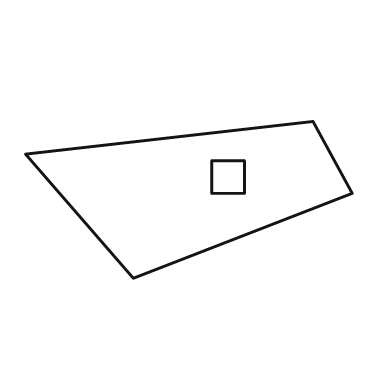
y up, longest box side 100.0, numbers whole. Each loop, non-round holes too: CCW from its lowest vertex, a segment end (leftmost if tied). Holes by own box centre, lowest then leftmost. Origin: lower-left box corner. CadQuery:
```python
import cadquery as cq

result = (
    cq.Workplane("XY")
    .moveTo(33.0, 0.0)
    .lineTo(100.0, 26.0)
    .lineTo(88.0, 48.0)
    .lineTo(0.0, 38.0)
    .close()
    .moveTo(57.0, 26.0)
    .lineTo(67.0, 26.0)
    .lineTo(67.0, 36.0)
    .lineTo(57.0, 36.0)
    .close()
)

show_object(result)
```